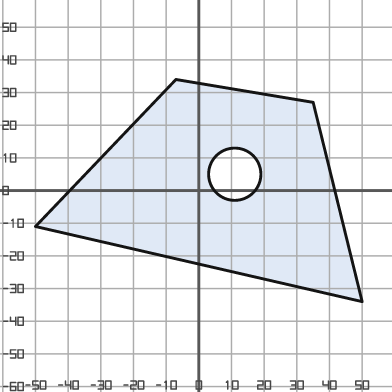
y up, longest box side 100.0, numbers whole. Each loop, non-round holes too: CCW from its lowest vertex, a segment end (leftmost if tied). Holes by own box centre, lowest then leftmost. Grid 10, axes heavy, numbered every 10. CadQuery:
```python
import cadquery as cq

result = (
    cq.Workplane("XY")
    .moveTo(50.0, -34.0)
    .lineTo(35.0, 27.0)
    .lineTo(-7.0, 34.0)
    .lineTo(-50.0, -11.0)
    .close()
    .moveTo(11.0, 5.0)
    .circle(8.0)
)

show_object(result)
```